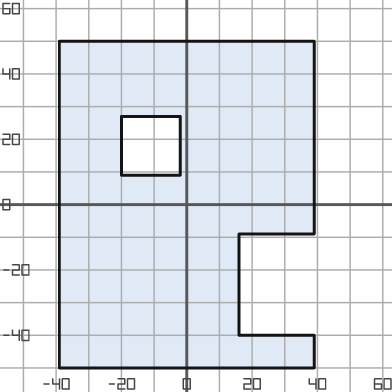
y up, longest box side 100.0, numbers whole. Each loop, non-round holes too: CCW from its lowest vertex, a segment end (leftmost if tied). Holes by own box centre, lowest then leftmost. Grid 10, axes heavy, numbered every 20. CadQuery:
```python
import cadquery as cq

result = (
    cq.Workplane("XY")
    .moveTo(-39.0, -50.0)
    .lineTo(39.0, -50.0)
    .lineTo(39.0, -40.0)
    .lineTo(16.0, -40.0)
    .lineTo(16.0, -9.0)
    .lineTo(39.0, -9.0)
    .lineTo(39.0, 50.0)
    .lineTo(-39.0, 50.0)
    .close()
    .moveTo(-20.0, 9.0)
    .lineTo(-2.0, 9.0)
    .lineTo(-2.0, 27.0)
    .lineTo(-20.0, 27.0)
    .close()
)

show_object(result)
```